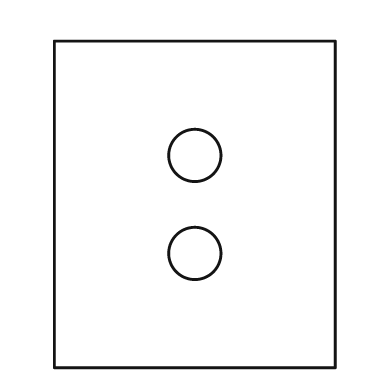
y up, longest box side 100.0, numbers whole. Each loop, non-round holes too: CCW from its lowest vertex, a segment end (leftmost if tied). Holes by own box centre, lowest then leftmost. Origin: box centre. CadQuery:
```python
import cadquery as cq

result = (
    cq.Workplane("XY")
    .moveTo(-43.0, -50.0)
    .lineTo(43.0, -50.0)
    .lineTo(43.0, 50.0)
    .lineTo(-43.0, 50.0)
    .close()
    .moveTo(0.0, -15.0)
    .circle(8.0)
    .moveTo(0.0, 15.0)
    .circle(8.0)
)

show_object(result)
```